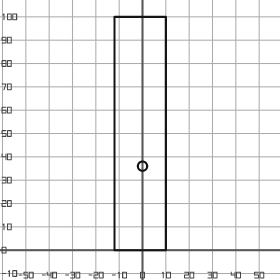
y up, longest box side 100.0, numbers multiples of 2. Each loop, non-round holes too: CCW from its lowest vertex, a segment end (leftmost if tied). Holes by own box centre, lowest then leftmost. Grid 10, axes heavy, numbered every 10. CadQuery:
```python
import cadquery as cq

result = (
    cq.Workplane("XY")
    .moveTo(-12.0, 0.0)
    .lineTo(10.0, 0.0)
    .lineTo(10.0, 100.0)
    .lineTo(-12.0, 100.0)
    .close()
    .moveTo(0.0, 36.0)
    .circle(2.0)
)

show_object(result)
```